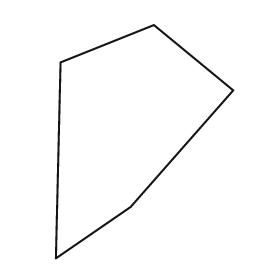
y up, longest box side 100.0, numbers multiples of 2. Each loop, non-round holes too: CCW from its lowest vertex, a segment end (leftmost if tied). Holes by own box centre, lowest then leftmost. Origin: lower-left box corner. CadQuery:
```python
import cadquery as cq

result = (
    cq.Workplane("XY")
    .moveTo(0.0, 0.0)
    .lineTo(32.0, 22.0)
    .lineTo(76.0, 72.0)
    .lineTo(42.0, 100.0)
    .lineTo(2.0, 84.0)
    .close()
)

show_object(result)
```